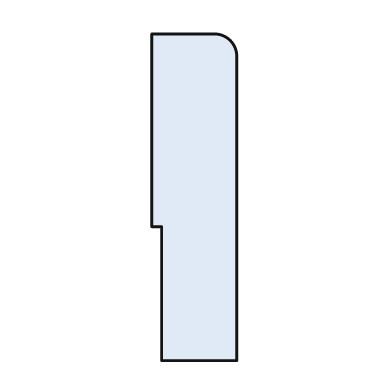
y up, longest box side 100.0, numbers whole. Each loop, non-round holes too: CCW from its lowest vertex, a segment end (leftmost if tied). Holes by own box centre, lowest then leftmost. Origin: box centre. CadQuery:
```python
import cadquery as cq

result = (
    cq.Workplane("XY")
    .moveTo(-10.0, -50.0)
    .lineTo(13.0, -50.0)
    .lineTo(13.0, 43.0)
    .threePointArc((11.0, 48.0), (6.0, 50.0))
    .lineTo(-13.0, 50.0)
    .lineTo(-13.0, -9.0)
    .lineTo(-10.0, -9.0)
    .close()
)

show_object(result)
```